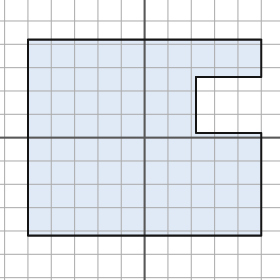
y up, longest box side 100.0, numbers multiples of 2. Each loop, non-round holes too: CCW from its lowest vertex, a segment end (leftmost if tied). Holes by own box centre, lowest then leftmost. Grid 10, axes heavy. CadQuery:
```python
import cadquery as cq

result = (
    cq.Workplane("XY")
    .moveTo(-50.0, -42.0)
    .lineTo(50.0, -42.0)
    .lineTo(50.0, 2.0)
    .lineTo(22.0, 2.0)
    .lineTo(22.0, 26.0)
    .lineTo(50.0, 26.0)
    .lineTo(50.0, 42.0)
    .lineTo(-50.0, 42.0)
    .close()
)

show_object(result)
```